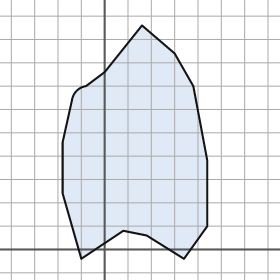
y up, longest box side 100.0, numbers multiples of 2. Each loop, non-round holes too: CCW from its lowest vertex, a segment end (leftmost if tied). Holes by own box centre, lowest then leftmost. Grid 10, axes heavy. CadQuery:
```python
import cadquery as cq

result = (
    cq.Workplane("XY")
    .moveTo(-10.0, -4.0)
    .lineTo(8.0, 8.0)
    .lineTo(18.0, 6.0)
    .lineTo(34.0, -4.0)
    .lineTo(44.0, 10.0)
    .lineTo(44.0, 38.0)
    .lineTo(38.0, 70.0)
    .lineTo(30.0, 84.0)
    .lineTo(16.0, 96.0)
    .lineTo(0.0, 76.0)
    .lineTo(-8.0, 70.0)
    .threePointArc((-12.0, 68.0), (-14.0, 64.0))
    .lineTo(-18.0, 46.0)
    .lineTo(-18.0, 24.0)
    .close()
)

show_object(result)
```